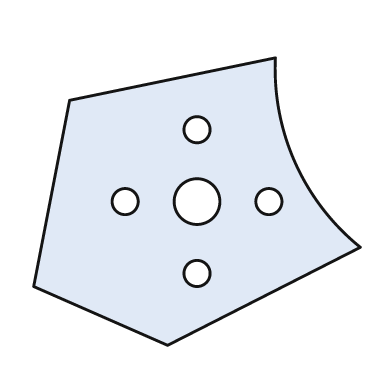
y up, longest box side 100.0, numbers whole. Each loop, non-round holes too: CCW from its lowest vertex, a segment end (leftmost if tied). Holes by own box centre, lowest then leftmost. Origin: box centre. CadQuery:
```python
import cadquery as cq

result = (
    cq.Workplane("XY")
    .moveTo(-9.0, -44.0)
    .lineTo(50.0, -14.0)
    .threePointArc((30.0, 12.0), (24.0, 44.0))
    .lineTo(-39.0, 31.0)
    .lineTo(-50.0, -26.0)
    .close()
    .moveTo(0.0, -22.0)
    .circle(4.0)
    .moveTo(-22.0, 0.0)
    .circle(4.0)
    .moveTo(0.0, 0.0)
    .circle(7.0)
    .moveTo(22.0, 0.0)
    .circle(4.0)
    .moveTo(0.0, 22.0)
    .circle(4.0)
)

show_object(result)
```